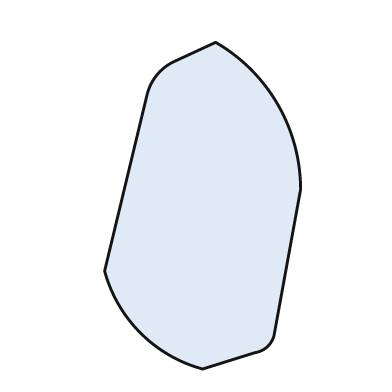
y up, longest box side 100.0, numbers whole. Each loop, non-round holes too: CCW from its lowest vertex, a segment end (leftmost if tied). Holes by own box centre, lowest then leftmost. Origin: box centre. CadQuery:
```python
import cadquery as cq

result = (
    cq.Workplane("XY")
    .moveTo(0.0, -50.0)
    .lineTo(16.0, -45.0)
    .threePointArc((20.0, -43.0), (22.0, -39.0))
    .lineTo(30.0, 5.0)
    .threePointArc((23.0, 31.0), (4.0, 50.0))
    .lineTo(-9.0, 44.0)
    .threePointArc((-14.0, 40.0), (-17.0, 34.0))
    .lineTo(-30.0, -20.0)
    .threePointArc((-19.0, -39.0), (0.0, -50.0))
    .close()
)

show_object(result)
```